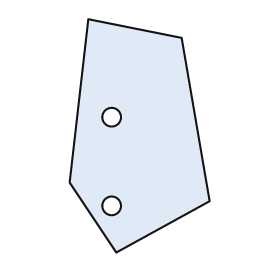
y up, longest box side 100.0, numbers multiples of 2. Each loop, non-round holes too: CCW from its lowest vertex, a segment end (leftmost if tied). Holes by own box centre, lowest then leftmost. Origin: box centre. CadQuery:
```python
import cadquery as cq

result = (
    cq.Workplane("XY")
    .moveTo(-10.0, -50.0)
    .lineTo(30.0, -28.0)
    .lineTo(18.0, 42.0)
    .lineTo(-22.0, 50.0)
    .lineTo(-30.0, -20.0)
    .close()
    .moveTo(-12.0, -30.0)
    .circle(4.0)
    .moveTo(-12.0, 8.0)
    .circle(4.0)
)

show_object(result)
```